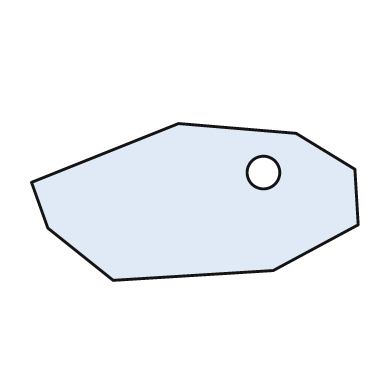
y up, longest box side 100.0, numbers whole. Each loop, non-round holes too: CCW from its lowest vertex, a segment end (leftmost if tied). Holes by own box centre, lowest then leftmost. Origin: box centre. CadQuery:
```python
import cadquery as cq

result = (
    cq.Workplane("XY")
    .moveTo(-25.0, -24.0)
    .lineTo(24.0, -21.0)
    .lineTo(50.0, -7.0)
    .lineTo(49.0, 10.0)
    .lineTo(31.0, 21.0)
    .lineTo(-5.0, 24.0)
    .lineTo(-50.0, 6.0)
    .lineTo(-45.0, -8.0)
    .close()
    .moveTo(21.0, 9.0)
    .circle(5.0)
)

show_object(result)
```